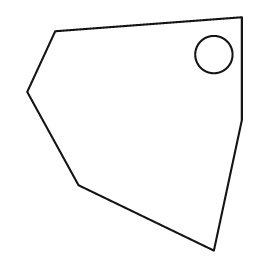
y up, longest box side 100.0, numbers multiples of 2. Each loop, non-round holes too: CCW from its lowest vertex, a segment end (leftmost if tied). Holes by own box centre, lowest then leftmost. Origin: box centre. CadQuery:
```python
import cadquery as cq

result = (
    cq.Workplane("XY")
    .moveTo(34.0, -50.0)
    .lineTo(46.0, 6.0)
    .lineTo(46.0, 50.0)
    .lineTo(-34.0, 44.0)
    .lineTo(-46.0, 18.0)
    .lineTo(-24.0, -22.0)
    .close()
    .moveTo(34.0, 34.0)
    .circle(8.0)
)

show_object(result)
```